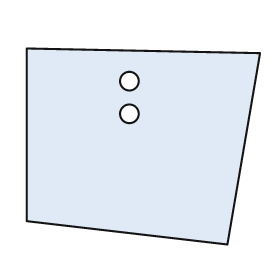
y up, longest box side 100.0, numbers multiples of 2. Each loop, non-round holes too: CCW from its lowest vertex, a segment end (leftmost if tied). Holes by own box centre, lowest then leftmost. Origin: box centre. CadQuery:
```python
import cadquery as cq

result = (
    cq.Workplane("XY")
    .moveTo(36.0, -42.0)
    .lineTo(50.0, 40.0)
    .lineTo(-50.0, 42.0)
    .lineTo(-50.0, -32.0)
    .close()
    .moveTo(-6.0, 14.0)
    .circle(4.0)
    .moveTo(-6.0, 28.0)
    .circle(4.0)
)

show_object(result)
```